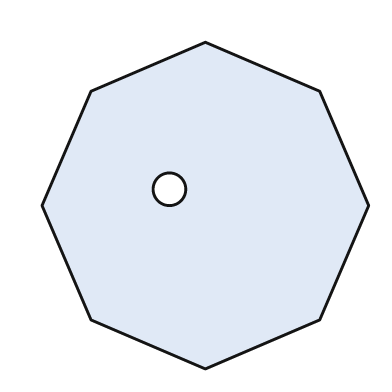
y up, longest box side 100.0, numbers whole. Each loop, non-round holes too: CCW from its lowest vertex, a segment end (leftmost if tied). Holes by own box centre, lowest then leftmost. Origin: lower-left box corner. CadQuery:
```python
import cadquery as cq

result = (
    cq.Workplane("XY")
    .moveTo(50.0, 0.0)
    .lineTo(85.0, 15.0)
    .lineTo(100.0, 50.0)
    .lineTo(85.0, 85.0)
    .lineTo(50.0, 100.0)
    .lineTo(15.0, 85.0)
    .lineTo(0.0, 50.0)
    .lineTo(15.0, 15.0)
    .close()
    .moveTo(39.0, 55.0)
    .circle(5.0)
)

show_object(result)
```